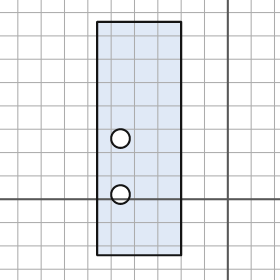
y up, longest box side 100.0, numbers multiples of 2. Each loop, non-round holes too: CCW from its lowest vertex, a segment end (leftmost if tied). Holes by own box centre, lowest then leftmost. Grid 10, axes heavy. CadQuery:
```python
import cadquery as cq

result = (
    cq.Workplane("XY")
    .moveTo(-56.0, -24.0)
    .lineTo(-20.0, -24.0)
    .lineTo(-20.0, 76.0)
    .lineTo(-56.0, 76.0)
    .close()
    .moveTo(-46.0, 2.0)
    .circle(4.0)
    .moveTo(-46.0, 26.0)
    .circle(4.0)
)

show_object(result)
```